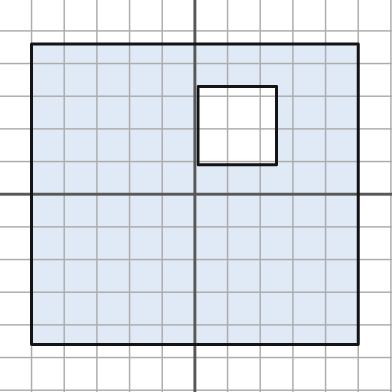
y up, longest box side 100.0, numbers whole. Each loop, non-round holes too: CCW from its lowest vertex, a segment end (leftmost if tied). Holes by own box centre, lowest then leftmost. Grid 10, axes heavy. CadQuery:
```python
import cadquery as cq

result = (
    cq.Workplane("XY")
    .moveTo(-50.0, -46.0)
    .lineTo(50.0, -46.0)
    .lineTo(50.0, 46.0)
    .lineTo(-50.0, 46.0)
    .close()
    .moveTo(1.0, 9.0)
    .lineTo(25.0, 9.0)
    .lineTo(25.0, 33.0)
    .lineTo(1.0, 33.0)
    .close()
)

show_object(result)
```